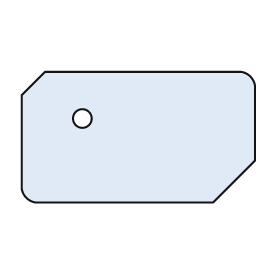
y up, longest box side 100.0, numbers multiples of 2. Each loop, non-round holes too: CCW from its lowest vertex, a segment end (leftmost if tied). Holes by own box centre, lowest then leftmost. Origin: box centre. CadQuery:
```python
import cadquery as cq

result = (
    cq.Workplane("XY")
    .moveTo(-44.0, -28.0)
    .lineTo(32.0, -28.0)
    .lineTo(50.0, -10.0)
    .lineTo(50.0, 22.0)
    .threePointArc((48.0, 26.0), (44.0, 28.0))
    .lineTo(-40.0, 28.0)
    .lineTo(-50.0, 18.0)
    .lineTo(-50.0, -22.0)
    .threePointArc((-48.0, -26.0), (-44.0, -28.0))
    .close()
    .moveTo(-24.0, 8.0)
    .circle(4.0)
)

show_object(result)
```